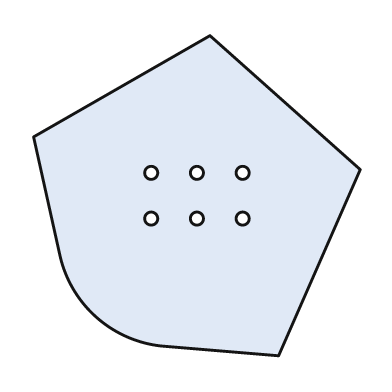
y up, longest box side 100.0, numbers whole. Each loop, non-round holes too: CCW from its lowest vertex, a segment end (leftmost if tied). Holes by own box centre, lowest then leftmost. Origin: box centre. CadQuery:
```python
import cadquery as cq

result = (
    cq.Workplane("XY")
    .moveTo(25.0, -49.0)
    .lineTo(50.0, 8.0)
    .lineTo(4.0, 49.0)
    .lineTo(-50.0, 18.0)
    .lineTo(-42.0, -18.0)
    .threePointArc((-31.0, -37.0), (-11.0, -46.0))
    .close()
    .moveTo(-14.0, -7.0)
    .circle(2.0)
    .moveTo(0.0, -7.0)
    .circle(2.0)
    .moveTo(14.0, -7.0)
    .circle(2.0)
    .moveTo(-14.0, 7.0)
    .circle(2.0)
    .moveTo(0.0, 7.0)
    .circle(2.0)
    .moveTo(14.0, 7.0)
    .circle(2.0)
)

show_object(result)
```